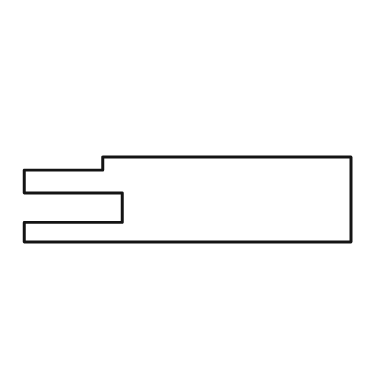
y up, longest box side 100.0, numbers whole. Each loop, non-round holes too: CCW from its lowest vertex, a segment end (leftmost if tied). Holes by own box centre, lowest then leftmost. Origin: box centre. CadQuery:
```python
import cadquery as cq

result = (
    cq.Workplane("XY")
    .moveTo(-50.0, -13.0)
    .lineTo(50.0, -13.0)
    .lineTo(50.0, 13.0)
    .lineTo(-26.0, 13.0)
    .lineTo(-26.0, 9.0)
    .lineTo(-50.0, 9.0)
    .lineTo(-50.0, 2.0)
    .lineTo(-20.0, 2.0)
    .lineTo(-20.0, -7.0)
    .lineTo(-50.0, -7.0)
    .close()
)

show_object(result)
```